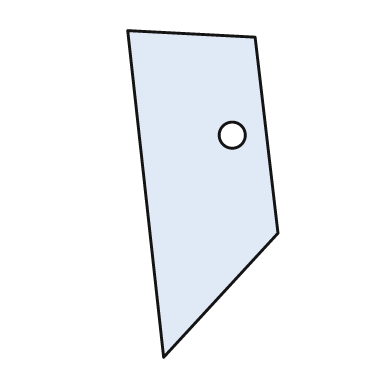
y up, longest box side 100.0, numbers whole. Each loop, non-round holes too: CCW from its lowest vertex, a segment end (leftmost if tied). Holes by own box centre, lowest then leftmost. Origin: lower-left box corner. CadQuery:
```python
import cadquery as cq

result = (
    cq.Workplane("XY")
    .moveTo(11.0, 0.0)
    .lineTo(46.0, 38.0)
    .lineTo(39.0, 98.0)
    .lineTo(0.0, 100.0)
    .close()
    .moveTo(32.0, 68.0)
    .circle(4.0)
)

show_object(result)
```